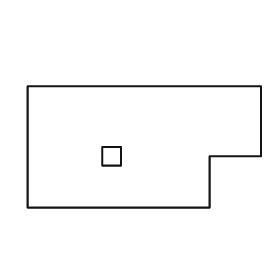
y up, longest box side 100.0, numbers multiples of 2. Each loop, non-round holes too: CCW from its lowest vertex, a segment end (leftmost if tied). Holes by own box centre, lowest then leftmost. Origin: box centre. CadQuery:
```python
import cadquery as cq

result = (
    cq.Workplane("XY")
    .moveTo(-50.0, -26.0)
    .lineTo(28.0, -26.0)
    .lineTo(28.0, -4.0)
    .lineTo(50.0, -4.0)
    .lineTo(50.0, 26.0)
    .lineTo(-50.0, 26.0)
    .close()
    .moveTo(-18.0, -8.0)
    .lineTo(-10.0, -8.0)
    .lineTo(-10.0, 0.0)
    .lineTo(-18.0, 0.0)
    .close()
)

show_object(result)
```